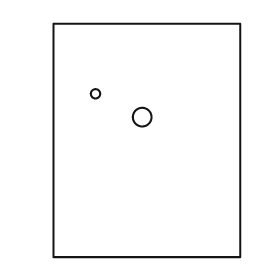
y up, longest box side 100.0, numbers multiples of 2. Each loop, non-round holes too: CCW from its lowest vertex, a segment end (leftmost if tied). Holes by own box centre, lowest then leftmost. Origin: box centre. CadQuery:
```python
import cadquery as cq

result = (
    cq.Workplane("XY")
    .moveTo(-40.0, -50.0)
    .lineTo(40.0, -50.0)
    .lineTo(40.0, 50.0)
    .lineTo(-40.0, 50.0)
    .close()
    .moveTo(-2.0, 10.0)
    .circle(4.0)
    .moveTo(-22.0, 20.0)
    .circle(2.0)
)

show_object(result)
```